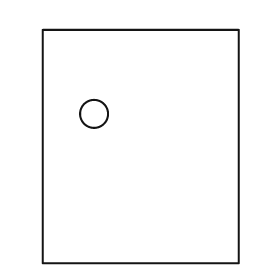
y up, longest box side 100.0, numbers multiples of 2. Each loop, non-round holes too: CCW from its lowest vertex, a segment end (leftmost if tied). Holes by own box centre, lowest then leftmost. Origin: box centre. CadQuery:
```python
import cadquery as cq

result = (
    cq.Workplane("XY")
    .moveTo(-42.0, -50.0)
    .lineTo(42.0, -50.0)
    .lineTo(42.0, 50.0)
    .lineTo(-42.0, 50.0)
    .close()
    .moveTo(-20.0, 14.0)
    .circle(6.0)
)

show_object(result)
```